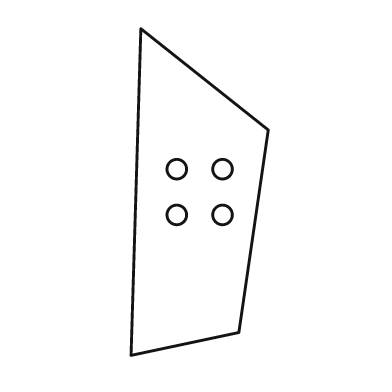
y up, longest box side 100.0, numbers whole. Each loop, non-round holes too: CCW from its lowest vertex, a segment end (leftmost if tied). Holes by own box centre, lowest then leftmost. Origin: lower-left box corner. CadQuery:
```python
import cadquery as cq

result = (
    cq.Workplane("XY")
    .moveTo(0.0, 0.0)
    .lineTo(33.0, 7.0)
    .lineTo(42.0, 69.0)
    .lineTo(3.0, 100.0)
    .close()
    .moveTo(14.0, 43.0)
    .circle(3.0)
    .moveTo(28.0, 43.0)
    .circle(3.0)
    .moveTo(14.0, 57.0)
    .circle(3.0)
    .moveTo(28.0, 57.0)
    .circle(3.0)
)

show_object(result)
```